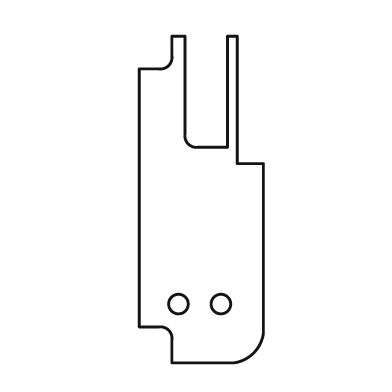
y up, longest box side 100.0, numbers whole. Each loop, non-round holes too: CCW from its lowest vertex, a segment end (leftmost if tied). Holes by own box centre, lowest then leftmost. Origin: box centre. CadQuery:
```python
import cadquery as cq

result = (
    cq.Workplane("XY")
    .moveTo(-9.0, -50.0)
    .lineTo(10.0, -50.0)
    .threePointArc((16.0, -47.0), (19.0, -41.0))
    .lineTo(19.0, 11.0)
    .lineTo(11.0, 11.0)
    .lineTo(11.0, 50.0)
    .lineTo(8.0, 50.0)
    .lineTo(8.0, 16.0)
    .lineTo(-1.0, 16.0)
    .threePointArc((-4.0, 17.0), (-5.0, 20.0))
    .lineTo(-5.0, 50.0)
    .lineTo(-9.0, 50.0)
    .lineTo(-9.0, 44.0)
    .threePointArc((-10.0, 41.0), (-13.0, 40.0))
    .lineTo(-19.0, 40.0)
    .lineTo(-19.0, -39.0)
    .lineTo(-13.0, -39.0)
    .threePointArc((-10.0, -40.0), (-9.0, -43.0))
    .close()
    .moveTo(-7.0, -32.0)
    .circle(3.0)
    .moveTo(6.0, -32.0)
    .circle(3.0)
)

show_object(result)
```